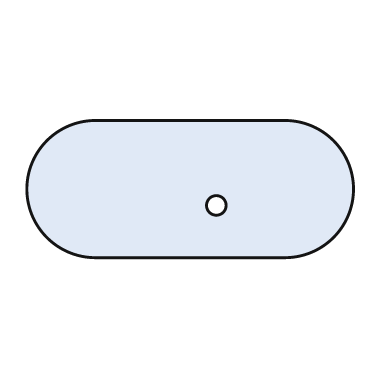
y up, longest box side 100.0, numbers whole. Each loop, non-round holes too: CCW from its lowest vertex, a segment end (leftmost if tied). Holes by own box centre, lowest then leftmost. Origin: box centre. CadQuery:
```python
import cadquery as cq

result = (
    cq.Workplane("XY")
    .moveTo(-29.0, -21.0)
    .lineTo(29.0, -21.0)
    .threePointArc((50.0, 0.0), (29.0, 21.0))
    .lineTo(-29.0, 21.0)
    .threePointArc((-50.0, 0.0), (-29.0, -21.0))
    .close()
    .moveTo(8.0, -5.0)
    .circle(3.0)
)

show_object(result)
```